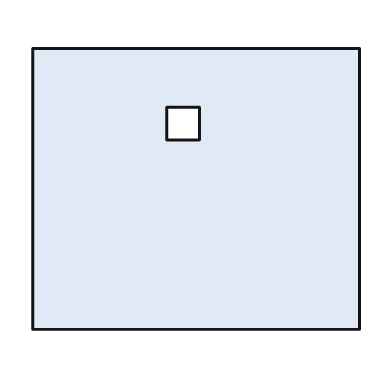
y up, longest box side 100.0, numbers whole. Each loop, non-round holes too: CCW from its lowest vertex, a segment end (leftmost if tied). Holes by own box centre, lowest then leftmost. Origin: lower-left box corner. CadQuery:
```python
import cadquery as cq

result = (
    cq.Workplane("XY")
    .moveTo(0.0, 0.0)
    .lineTo(100.0, 0.0)
    .lineTo(100.0, 86.0)
    .lineTo(0.0, 86.0)
    .close()
    .moveTo(41.0, 58.0)
    .lineTo(51.0, 58.0)
    .lineTo(51.0, 68.0)
    .lineTo(41.0, 68.0)
    .close()
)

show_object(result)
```